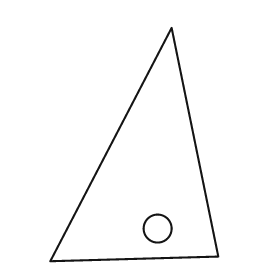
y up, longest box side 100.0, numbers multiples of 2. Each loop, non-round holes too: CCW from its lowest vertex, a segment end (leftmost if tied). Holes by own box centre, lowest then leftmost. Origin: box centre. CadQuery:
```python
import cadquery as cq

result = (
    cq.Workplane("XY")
    .moveTo(-36.0, -50.0)
    .lineTo(36.0, -48.0)
    .lineTo(16.0, 50.0)
    .close()
    .moveTo(10.0, -36.0)
    .circle(6.0)
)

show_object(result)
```